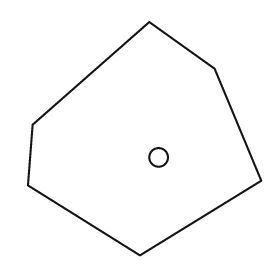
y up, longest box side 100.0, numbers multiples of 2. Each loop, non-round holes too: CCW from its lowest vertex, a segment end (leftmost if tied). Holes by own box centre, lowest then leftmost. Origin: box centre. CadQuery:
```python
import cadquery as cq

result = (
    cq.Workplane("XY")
    .moveTo(-2.0, -50.0)
    .lineTo(50.0, -18.0)
    .lineTo(30.0, 30.0)
    .lineTo(2.0, 50.0)
    .lineTo(-48.0, 6.0)
    .lineTo(-50.0, -20.0)
    .close()
    .moveTo(6.0, -8.0)
    .circle(4.0)
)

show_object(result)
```